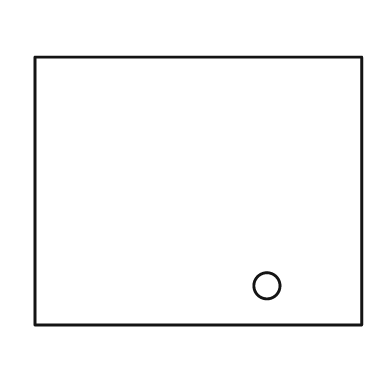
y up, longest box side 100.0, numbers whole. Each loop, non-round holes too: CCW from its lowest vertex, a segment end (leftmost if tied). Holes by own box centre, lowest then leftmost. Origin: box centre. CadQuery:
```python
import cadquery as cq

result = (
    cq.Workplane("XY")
    .moveTo(-50.0, -41.0)
    .lineTo(50.0, -41.0)
    .lineTo(50.0, 41.0)
    .lineTo(-50.0, 41.0)
    .close()
    .moveTo(21.0, -29.0)
    .circle(4.0)
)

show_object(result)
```